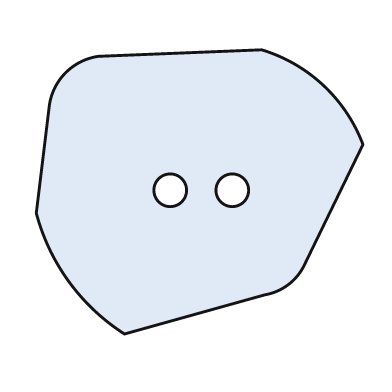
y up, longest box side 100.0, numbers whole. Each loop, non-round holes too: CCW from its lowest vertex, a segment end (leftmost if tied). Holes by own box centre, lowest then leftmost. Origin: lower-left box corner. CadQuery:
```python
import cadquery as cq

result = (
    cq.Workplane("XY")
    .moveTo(27.0, 0.0)
    .lineTo(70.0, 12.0)
    .threePointArc((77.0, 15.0), (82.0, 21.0))
    .lineTo(100.0, 58.0)
    .threePointArc((88.0, 76.0), (69.0, 87.0))
    .lineTo(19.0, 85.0)
    .threePointArc((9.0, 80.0), (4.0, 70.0))
    .lineTo(0.0, 37.0)
    .threePointArc((10.0, 16.0), (27.0, 0.0))
    .close()
    .moveTo(41.0, 44.0)
    .circle(5.0)
    .moveTo(60.0, 44.0)
    .circle(5.0)
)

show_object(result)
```